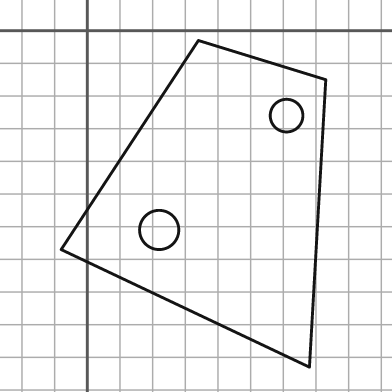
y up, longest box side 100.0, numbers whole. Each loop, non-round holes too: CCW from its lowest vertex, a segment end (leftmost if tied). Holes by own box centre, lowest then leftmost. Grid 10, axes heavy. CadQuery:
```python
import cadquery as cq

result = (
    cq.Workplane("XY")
    .moveTo(68.0, -103.0)
    .lineTo(73.0, -15.0)
    .lineTo(34.0, -3.0)
    .lineTo(-8.0, -67.0)
    .close()
    .moveTo(22.0, -61.0)
    .circle(6.0)
    .moveTo(61.0, -26.0)
    .circle(5.0)
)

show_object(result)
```